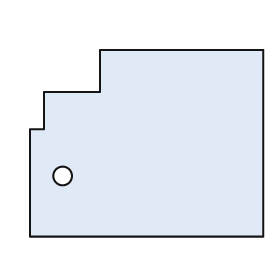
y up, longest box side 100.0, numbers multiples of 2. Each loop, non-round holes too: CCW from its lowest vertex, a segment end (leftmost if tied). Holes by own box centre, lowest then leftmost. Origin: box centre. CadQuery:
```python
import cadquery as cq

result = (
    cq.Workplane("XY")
    .moveTo(-50.0, -40.0)
    .lineTo(50.0, -40.0)
    .lineTo(50.0, 40.0)
    .lineTo(-20.0, 40.0)
    .lineTo(-20.0, 22.0)
    .lineTo(-44.0, 22.0)
    .lineTo(-44.0, 6.0)
    .lineTo(-50.0, 6.0)
    .close()
    .moveTo(-36.0, -14.0)
    .circle(4.0)
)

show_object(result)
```